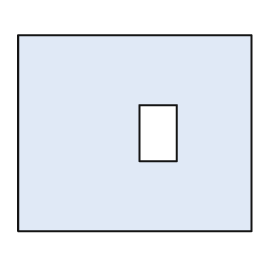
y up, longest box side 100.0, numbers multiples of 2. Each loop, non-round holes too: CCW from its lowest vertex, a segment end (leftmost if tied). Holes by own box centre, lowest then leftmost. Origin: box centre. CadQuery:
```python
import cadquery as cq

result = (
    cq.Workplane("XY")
    .moveTo(-50.0, -42.0)
    .lineTo(50.0, -42.0)
    .lineTo(50.0, 42.0)
    .lineTo(-50.0, 42.0)
    .close()
    .moveTo(2.0, -12.0)
    .lineTo(18.0, -12.0)
    .lineTo(18.0, 12.0)
    .lineTo(2.0, 12.0)
    .close()
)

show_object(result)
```